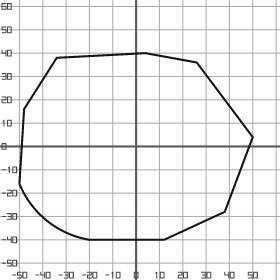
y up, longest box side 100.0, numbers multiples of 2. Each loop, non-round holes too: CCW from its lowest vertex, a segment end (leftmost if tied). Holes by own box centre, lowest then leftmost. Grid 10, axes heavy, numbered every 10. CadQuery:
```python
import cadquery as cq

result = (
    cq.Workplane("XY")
    .moveTo(-20.0, -40.0)
    .lineTo(12.0, -40.0)
    .lineTo(38.0, -28.0)
    .lineTo(50.0, 4.0)
    .lineTo(26.0, 36.0)
    .lineTo(4.0, 40.0)
    .lineTo(-34.0, 38.0)
    .lineTo(-48.0, 16.0)
    .lineTo(-50.0, -16.0)
    .threePointArc((-38.0, -32.0), (-20.0, -40.0))
    .close()
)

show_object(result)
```